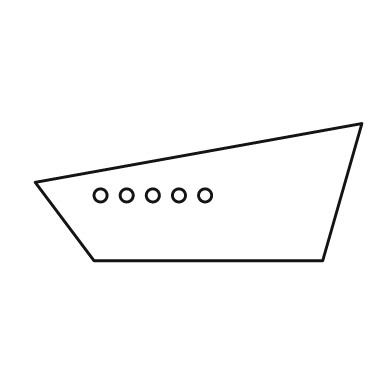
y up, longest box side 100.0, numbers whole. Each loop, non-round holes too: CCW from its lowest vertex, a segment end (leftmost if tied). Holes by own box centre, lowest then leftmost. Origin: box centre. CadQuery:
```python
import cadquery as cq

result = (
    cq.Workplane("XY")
    .moveTo(-32.0, -21.0)
    .lineTo(38.0, -21.0)
    .lineTo(50.0, 21.0)
    .lineTo(-50.0, 3.0)
    .close()
    .moveTo(-30.0, -1.0)
    .circle(2.0)
    .moveTo(-22.0, -1.0)
    .circle(2.0)
    .moveTo(-14.0, -1.0)
    .circle(2.0)
    .moveTo(-6.0, -1.0)
    .circle(2.0)
    .moveTo(2.0, -1.0)
    .circle(2.0)
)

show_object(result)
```